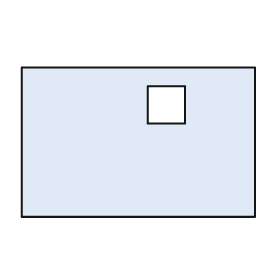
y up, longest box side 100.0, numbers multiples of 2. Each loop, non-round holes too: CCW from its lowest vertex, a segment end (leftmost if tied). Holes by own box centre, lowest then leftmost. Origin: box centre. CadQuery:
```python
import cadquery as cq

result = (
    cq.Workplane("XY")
    .moveTo(-50.0, -32.0)
    .lineTo(50.0, -32.0)
    .lineTo(50.0, 32.0)
    .lineTo(-50.0, 32.0)
    .close()
    .moveTo(4.0, 8.0)
    .lineTo(20.0, 8.0)
    .lineTo(20.0, 24.0)
    .lineTo(4.0, 24.0)
    .close()
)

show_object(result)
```